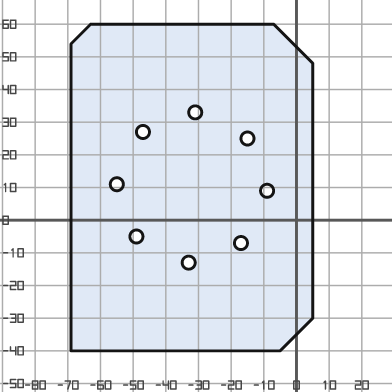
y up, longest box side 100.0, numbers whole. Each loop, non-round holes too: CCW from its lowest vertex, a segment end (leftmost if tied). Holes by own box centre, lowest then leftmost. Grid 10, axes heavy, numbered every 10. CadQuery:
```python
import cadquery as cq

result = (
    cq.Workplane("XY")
    .moveTo(-69.0, -40.0)
    .lineTo(-5.0, -40.0)
    .lineTo(5.0, -30.0)
    .lineTo(5.0, 48.0)
    .lineTo(-7.0, 60.0)
    .lineTo(-63.0, 60.0)
    .lineTo(-69.0, 54.0)
    .close()
    .moveTo(-33.0, -13.0)
    .circle(2.0)
    .moveTo(-17.0, -7.0)
    .circle(2.0)
    .moveTo(-49.0, -5.0)
    .circle(2.0)
    .moveTo(-9.0, 9.0)
    .circle(2.0)
    .moveTo(-55.0, 11.0)
    .circle(2.0)
    .moveTo(-15.0, 25.0)
    .circle(2.0)
    .moveTo(-47.0, 27.0)
    .circle(2.0)
    .moveTo(-31.0, 33.0)
    .circle(2.0)
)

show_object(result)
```